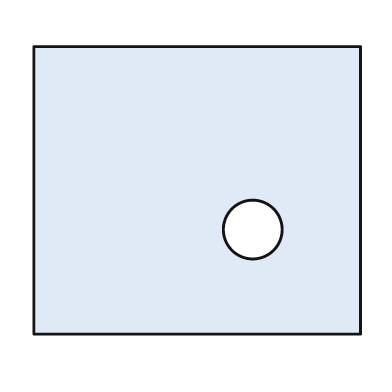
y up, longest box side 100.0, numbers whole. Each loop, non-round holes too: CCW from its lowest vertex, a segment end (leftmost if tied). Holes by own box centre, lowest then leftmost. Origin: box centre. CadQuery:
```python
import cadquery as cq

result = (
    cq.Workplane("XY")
    .moveTo(-50.0, -44.0)
    .lineTo(50.0, -44.0)
    .lineTo(50.0, 44.0)
    .lineTo(-50.0, 44.0)
    .close()
    .moveTo(17.0, -12.0)
    .circle(9.0)
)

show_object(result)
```